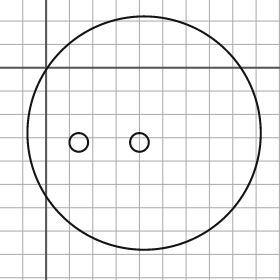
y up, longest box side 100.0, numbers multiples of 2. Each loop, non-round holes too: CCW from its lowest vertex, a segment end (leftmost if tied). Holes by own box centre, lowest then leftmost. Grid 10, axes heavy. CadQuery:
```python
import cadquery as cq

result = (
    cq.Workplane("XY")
    .moveTo(42.0, -28.0)
    .circle(50.0)
    .moveTo(14.0, -32.0)
    .circle(4.0)
    .moveTo(40.0, -32.0)
    .circle(4.0)
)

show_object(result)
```